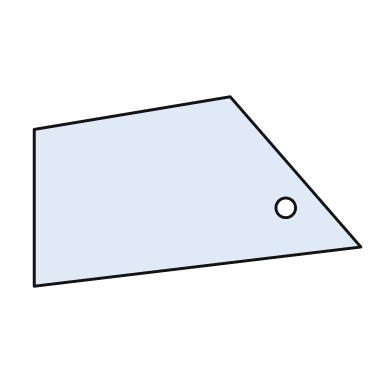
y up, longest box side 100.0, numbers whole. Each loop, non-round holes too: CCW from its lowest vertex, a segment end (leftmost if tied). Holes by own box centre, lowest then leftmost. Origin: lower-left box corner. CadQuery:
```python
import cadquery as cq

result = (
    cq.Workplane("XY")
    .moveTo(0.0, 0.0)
    .lineTo(100.0, 12.0)
    .lineTo(60.0, 58.0)
    .lineTo(0.0, 48.0)
    .close()
    .moveTo(77.0, 24.0)
    .circle(3.0)
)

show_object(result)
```